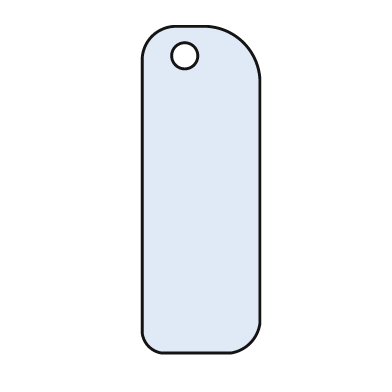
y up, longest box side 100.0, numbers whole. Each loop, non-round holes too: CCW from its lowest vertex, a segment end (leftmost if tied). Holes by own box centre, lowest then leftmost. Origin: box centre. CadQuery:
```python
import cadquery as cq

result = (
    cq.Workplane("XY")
    .moveTo(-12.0, -50.0)
    .lineTo(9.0, -50.0)
    .threePointArc((15.0, -47.0), (18.0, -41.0))
    .lineTo(18.0, 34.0)
    .threePointArc((13.0, 45.0), (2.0, 50.0))
    .lineTo(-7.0, 50.0)
    .threePointArc((-15.0, 47.0), (-18.0, 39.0))
    .lineTo(-18.0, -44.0)
    .threePointArc((-16.0, -48.0), (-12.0, -50.0))
    .close()
    .moveTo(-5.0, 41.0)
    .circle(4.0)
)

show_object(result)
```